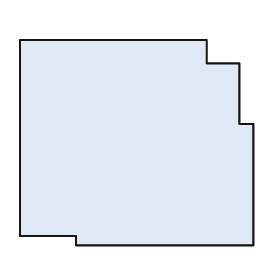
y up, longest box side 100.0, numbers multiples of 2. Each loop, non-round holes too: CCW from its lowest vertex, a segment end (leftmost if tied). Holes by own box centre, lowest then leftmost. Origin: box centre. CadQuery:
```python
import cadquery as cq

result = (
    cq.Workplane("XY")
    .moveTo(-26.0, -44.0)
    .lineTo(50.0, -44.0)
    .lineTo(50.0, 8.0)
    .lineTo(44.0, 8.0)
    .lineTo(44.0, 34.0)
    .lineTo(30.0, 34.0)
    .lineTo(30.0, 44.0)
    .lineTo(-50.0, 44.0)
    .lineTo(-50.0, -40.0)
    .lineTo(-26.0, -40.0)
    .close()
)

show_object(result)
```